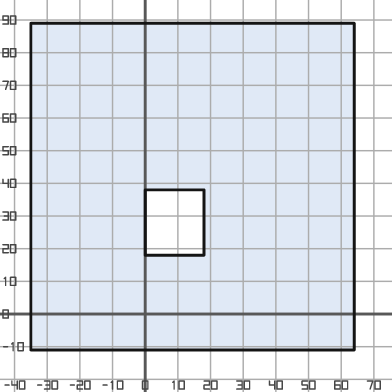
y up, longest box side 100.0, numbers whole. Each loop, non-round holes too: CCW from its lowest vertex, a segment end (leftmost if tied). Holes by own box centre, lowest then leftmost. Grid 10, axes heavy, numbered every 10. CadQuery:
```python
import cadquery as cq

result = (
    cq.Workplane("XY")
    .moveTo(-35.0, -11.0)
    .lineTo(64.0, -11.0)
    .lineTo(64.0, 89.0)
    .lineTo(-35.0, 89.0)
    .close()
    .moveTo(0.0, 18.0)
    .lineTo(18.0, 18.0)
    .lineTo(18.0, 38.0)
    .lineTo(0.0, 38.0)
    .close()
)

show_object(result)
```